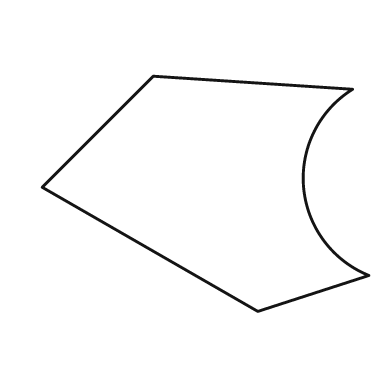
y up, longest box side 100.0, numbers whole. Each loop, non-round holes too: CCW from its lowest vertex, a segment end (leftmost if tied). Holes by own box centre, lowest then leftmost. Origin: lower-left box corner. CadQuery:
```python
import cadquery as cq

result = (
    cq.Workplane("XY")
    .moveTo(66.0, 0.0)
    .lineTo(100.0, 11.0)
    .threePointArc((80.0, 38.0), (95.0, 68.0))
    .lineTo(34.0, 72.0)
    .lineTo(0.0, 38.0)
    .close()
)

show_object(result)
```